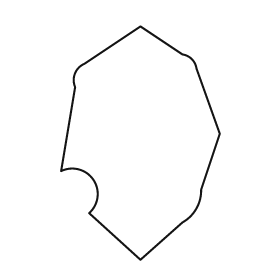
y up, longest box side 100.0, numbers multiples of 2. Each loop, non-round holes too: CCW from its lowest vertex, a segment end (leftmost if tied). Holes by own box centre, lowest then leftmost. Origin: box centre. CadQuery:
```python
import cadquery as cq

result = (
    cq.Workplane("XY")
    .moveTo(0.0, -50.0)
    .lineTo(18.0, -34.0)
    .threePointArc((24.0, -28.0), (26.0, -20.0))
    .lineTo(34.0, 4.0)
    .lineTo(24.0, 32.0)
    .threePointArc((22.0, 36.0), (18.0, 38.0))
    .lineTo(0.0, 50.0)
    .lineTo(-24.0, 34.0)
    .threePointArc((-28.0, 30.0), (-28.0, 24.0))
    .lineTo(-34.0, -12.0)
    .threePointArc((-20.0, -16.0), (-22.0, -30.0))
    .close()
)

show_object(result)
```